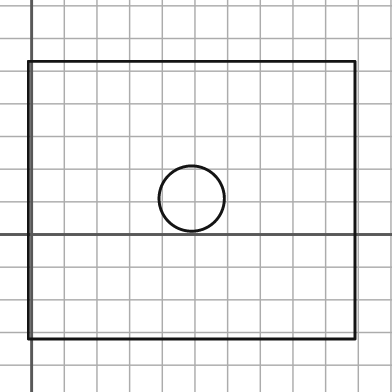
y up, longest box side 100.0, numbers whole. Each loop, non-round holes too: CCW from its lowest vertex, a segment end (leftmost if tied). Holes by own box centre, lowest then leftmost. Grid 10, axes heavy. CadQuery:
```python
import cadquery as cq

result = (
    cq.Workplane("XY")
    .moveTo(-1.0, -32.0)
    .lineTo(99.0, -32.0)
    .lineTo(99.0, 53.0)
    .lineTo(-1.0, 53.0)
    .close()
    .moveTo(49.0, 11.0)
    .circle(10.0)
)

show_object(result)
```